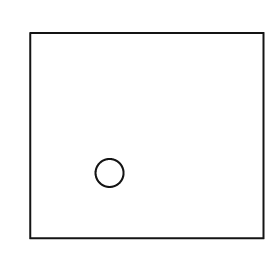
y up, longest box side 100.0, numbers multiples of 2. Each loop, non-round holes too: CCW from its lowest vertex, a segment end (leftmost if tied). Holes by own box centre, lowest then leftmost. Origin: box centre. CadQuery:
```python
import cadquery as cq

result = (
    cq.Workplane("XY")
    .moveTo(-50.0, -44.0)
    .lineTo(50.0, -44.0)
    .lineTo(50.0, 44.0)
    .lineTo(-50.0, 44.0)
    .close()
    .moveTo(-16.0, -16.0)
    .circle(6.0)
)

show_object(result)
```